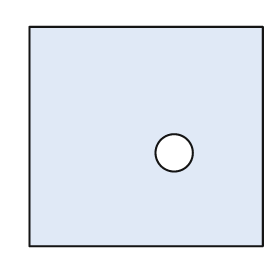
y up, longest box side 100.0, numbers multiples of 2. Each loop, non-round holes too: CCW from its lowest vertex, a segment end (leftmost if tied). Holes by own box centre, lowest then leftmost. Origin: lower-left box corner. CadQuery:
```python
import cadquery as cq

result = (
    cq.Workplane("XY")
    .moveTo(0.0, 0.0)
    .lineTo(100.0, 0.0)
    .lineTo(100.0, 94.0)
    .lineTo(0.0, 94.0)
    .close()
    .moveTo(62.0, 40.0)
    .circle(8.0)
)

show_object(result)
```